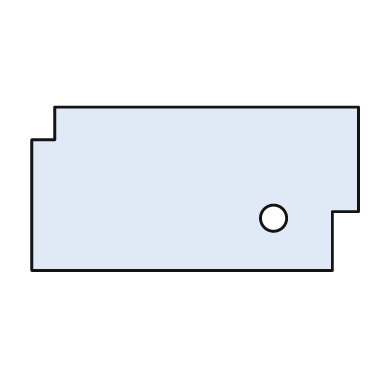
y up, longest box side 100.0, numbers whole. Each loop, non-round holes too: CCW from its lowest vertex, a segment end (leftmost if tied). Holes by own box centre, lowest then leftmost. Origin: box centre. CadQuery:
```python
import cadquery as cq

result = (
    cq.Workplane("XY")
    .moveTo(-50.0, -25.0)
    .lineTo(42.0, -25.0)
    .lineTo(42.0, -7.0)
    .lineTo(50.0, -7.0)
    .lineTo(50.0, 25.0)
    .lineTo(-43.0, 25.0)
    .lineTo(-43.0, 15.0)
    .lineTo(-50.0, 15.0)
    .close()
    .moveTo(24.0, -9.0)
    .circle(4.0)
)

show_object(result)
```